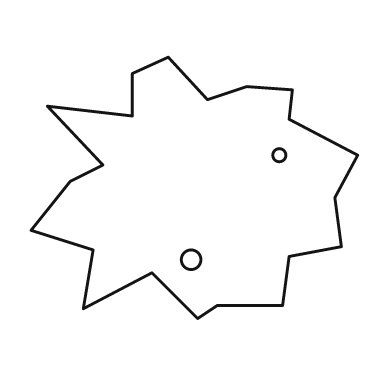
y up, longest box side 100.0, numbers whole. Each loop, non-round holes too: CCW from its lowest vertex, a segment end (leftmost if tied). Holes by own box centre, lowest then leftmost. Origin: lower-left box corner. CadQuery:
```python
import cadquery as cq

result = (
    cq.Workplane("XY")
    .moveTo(51.0, 0.0)
    .lineTo(57.0, 4.0)
    .lineTo(77.0, 4.0)
    .lineTo(79.0, 19.0)
    .lineTo(95.0, 22.0)
    .lineTo(93.0, 37.0)
    .lineTo(100.0, 50.0)
    .lineTo(79.0, 61.0)
    .lineTo(80.0, 70.0)
    .lineTo(66.0, 71.0)
    .lineTo(54.0, 67.0)
    .lineTo(42.0, 80.0)
    .lineTo(31.0, 75.0)
    .lineTo(31.0, 62.0)
    .lineTo(5.0, 65.0)
    .lineTo(22.0, 47.0)
    .lineTo(12.0, 42.0)
    .lineTo(0.0, 27.0)
    .lineTo(19.0, 21.0)
    .lineTo(16.0, 3.0)
    .lineTo(37.0, 14.0)
    .close()
    .moveTo(49.0, 18.0)
    .circle(3.0)
    .moveTo(76.0, 50.0)
    .circle(2.0)
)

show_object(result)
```